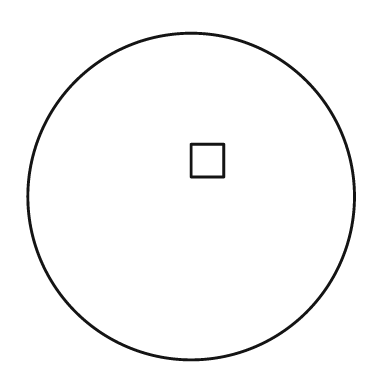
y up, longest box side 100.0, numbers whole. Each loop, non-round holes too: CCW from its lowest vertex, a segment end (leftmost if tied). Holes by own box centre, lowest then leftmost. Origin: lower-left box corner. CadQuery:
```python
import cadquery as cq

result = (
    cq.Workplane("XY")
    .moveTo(50.0, 50.0)
    .circle(50.0)
    .moveTo(50.0, 56.0)
    .lineTo(60.0, 56.0)
    .lineTo(60.0, 66.0)
    .lineTo(50.0, 66.0)
    .close()
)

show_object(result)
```